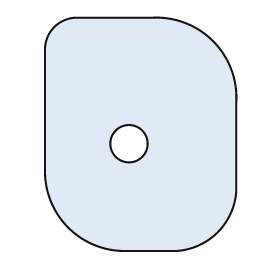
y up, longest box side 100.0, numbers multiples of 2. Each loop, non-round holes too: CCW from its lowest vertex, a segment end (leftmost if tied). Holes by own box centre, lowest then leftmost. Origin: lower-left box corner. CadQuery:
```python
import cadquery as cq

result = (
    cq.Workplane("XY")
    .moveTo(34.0, 0.0)
    .lineTo(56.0, 0.0)
    .threePointArc((74.0, 8.0), (82.0, 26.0))
    .lineTo(82.0, 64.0)
    .threePointArc((72.0, 90.0), (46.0, 100.0))
    .lineTo(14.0, 100.0)
    .threePointArc((4.0, 96.0), (0.0, 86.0))
    .lineTo(0.0, 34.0)
    .threePointArc((10.0, 10.0), (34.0, 0.0))
    .close()
    .moveTo(36.0, 46.0)
    .circle(8.0)
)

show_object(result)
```